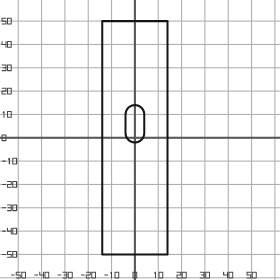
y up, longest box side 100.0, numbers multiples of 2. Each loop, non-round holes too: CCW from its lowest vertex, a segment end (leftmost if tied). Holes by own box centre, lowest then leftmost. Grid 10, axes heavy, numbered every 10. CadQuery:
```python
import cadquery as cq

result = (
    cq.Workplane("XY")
    .moveTo(-14.0, -50.0)
    .lineTo(14.0, -50.0)
    .lineTo(14.0, 50.0)
    .lineTo(-14.0, 50.0)
    .close()
    .moveTo(-4.0, 2.0)
    .threePointArc((0.0, -2.0), (4.0, 2.0))
    .lineTo(4.0, 10.0)
    .threePointArc((0.0, 14.0), (-4.0, 10.0))
    .close()
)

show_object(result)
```